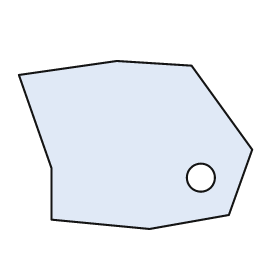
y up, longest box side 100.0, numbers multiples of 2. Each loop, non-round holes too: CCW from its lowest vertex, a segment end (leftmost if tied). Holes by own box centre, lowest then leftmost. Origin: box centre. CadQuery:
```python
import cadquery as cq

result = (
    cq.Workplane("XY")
    .moveTo(6.0, -36.0)
    .lineTo(40.0, -30.0)
    .lineTo(50.0, -2.0)
    .lineTo(24.0, 34.0)
    .lineTo(-8.0, 36.0)
    .lineTo(-50.0, 30.0)
    .lineTo(-36.0, -10.0)
    .lineTo(-36.0, -32.0)
    .close()
    .moveTo(28.0, -14.0)
    .circle(6.0)
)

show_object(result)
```